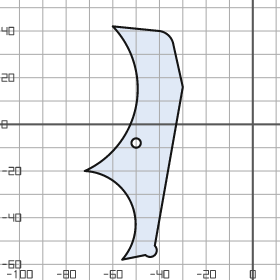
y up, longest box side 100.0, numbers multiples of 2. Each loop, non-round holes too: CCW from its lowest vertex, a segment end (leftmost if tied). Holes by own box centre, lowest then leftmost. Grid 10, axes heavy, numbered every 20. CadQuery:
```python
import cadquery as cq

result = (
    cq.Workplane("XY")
    .moveTo(-56.0, -58.0)
    .lineTo(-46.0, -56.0)
    .threePointArc((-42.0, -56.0), (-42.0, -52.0))
    .lineTo(-30.0, 16.0)
    .lineTo(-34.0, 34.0)
    .threePointArc((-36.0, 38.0), (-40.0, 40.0))
    .lineTo(-60.0, 42.0)
    .threePointArc((-50.0, 8.0), (-72.0, -20.0))
    .threePointArc((-52.0, -34.0), (-56.0, -58.0))
    .close()
    .moveTo(-50.0, -8.0)
    .circle(2.0)
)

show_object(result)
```